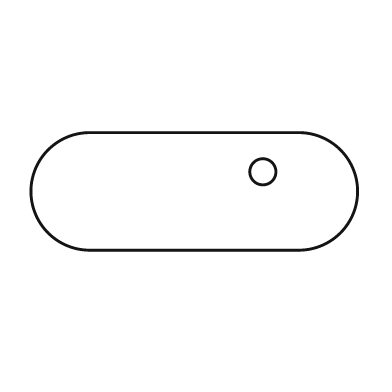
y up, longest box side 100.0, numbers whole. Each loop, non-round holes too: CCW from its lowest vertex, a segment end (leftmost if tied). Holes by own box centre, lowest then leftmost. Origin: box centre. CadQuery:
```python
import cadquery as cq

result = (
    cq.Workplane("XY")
    .moveTo(-32.0, -18.0)
    .lineTo(32.0, -18.0)
    .threePointArc((50.0, 0.0), (32.0, 18.0))
    .lineTo(-32.0, 18.0)
    .threePointArc((-50.0, 0.0), (-32.0, -18.0))
    .close()
    .moveTo(21.0, 6.0)
    .circle(4.0)
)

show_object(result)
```